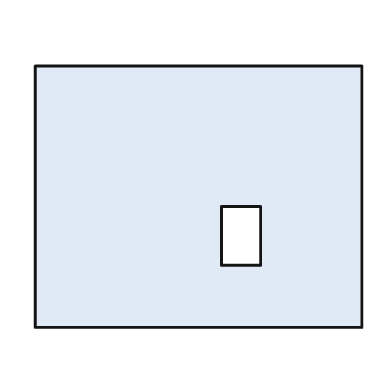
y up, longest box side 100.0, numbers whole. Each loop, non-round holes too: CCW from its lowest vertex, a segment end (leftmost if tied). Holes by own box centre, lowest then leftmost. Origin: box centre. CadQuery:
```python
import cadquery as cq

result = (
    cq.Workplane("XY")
    .moveTo(-50.0, -40.0)
    .lineTo(50.0, -40.0)
    .lineTo(50.0, 40.0)
    .lineTo(-50.0, 40.0)
    .close()
    .moveTo(7.0, -21.0)
    .lineTo(19.0, -21.0)
    .lineTo(19.0, -3.0)
    .lineTo(7.0, -3.0)
    .close()
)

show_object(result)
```